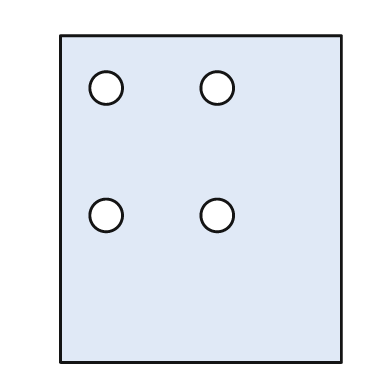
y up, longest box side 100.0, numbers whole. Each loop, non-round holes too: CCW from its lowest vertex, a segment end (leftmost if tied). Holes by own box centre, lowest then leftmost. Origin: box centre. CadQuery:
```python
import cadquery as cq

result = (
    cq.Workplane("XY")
    .moveTo(-43.0, -50.0)
    .lineTo(43.0, -50.0)
    .lineTo(43.0, 50.0)
    .lineTo(-43.0, 50.0)
    .close()
    .moveTo(-29.0, -5.0)
    .circle(5.0)
    .moveTo(5.0, -5.0)
    .circle(5.0)
    .moveTo(-29.0, 34.0)
    .circle(5.0)
    .moveTo(5.0, 34.0)
    .circle(5.0)
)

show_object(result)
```